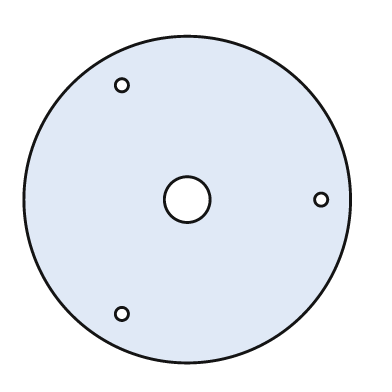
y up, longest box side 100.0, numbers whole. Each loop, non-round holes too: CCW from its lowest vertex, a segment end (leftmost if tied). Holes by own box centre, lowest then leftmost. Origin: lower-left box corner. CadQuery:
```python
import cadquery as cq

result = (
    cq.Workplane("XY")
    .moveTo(50.0, 50.0)
    .circle(50.0)
    .moveTo(30.0, 15.0)
    .circle(2.0)
    .moveTo(50.0, 50.0)
    .circle(7.0)
    .moveTo(91.0, 50.0)
    .circle(2.0)
    .moveTo(30.0, 85.0)
    .circle(2.0)
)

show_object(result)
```